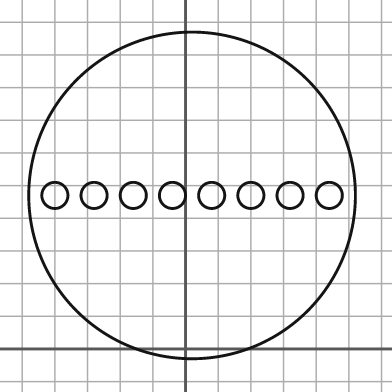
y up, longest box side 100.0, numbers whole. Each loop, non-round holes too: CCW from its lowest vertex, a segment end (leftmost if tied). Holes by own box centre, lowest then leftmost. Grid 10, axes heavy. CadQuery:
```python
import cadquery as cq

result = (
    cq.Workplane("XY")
    .moveTo(2.0, 47.0)
    .circle(50.0)
    .moveTo(-40.0, 47.0)
    .circle(4.0)
    .moveTo(-28.0, 47.0)
    .circle(4.0)
    .moveTo(-16.0, 47.0)
    .circle(4.0)
    .moveTo(-4.0, 47.0)
    .circle(4.0)
    .moveTo(8.0, 47.0)
    .circle(4.0)
    .moveTo(20.0, 47.0)
    .circle(4.0)
    .moveTo(32.0, 47.0)
    .circle(4.0)
    .moveTo(44.0, 47.0)
    .circle(4.0)
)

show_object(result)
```